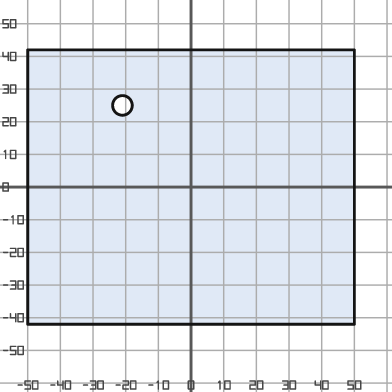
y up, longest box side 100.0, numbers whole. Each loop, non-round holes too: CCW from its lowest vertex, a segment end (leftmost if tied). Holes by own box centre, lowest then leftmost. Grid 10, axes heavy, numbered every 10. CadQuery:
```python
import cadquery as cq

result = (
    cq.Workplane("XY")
    .moveTo(-50.0, -42.0)
    .lineTo(50.0, -42.0)
    .lineTo(50.0, 42.0)
    .lineTo(-50.0, 42.0)
    .close()
    .moveTo(-21.0, 25.0)
    .circle(3.0)
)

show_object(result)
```